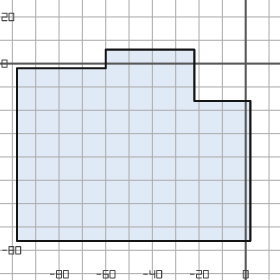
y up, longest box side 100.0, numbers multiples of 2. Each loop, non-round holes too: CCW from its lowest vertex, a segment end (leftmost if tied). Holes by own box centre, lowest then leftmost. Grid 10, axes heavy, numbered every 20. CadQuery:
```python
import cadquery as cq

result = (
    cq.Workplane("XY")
    .moveTo(-98.0, -76.0)
    .lineTo(2.0, -76.0)
    .lineTo(2.0, -16.0)
    .lineTo(-22.0, -16.0)
    .lineTo(-22.0, 6.0)
    .lineTo(-60.0, 6.0)
    .lineTo(-60.0, -2.0)
    .lineTo(-98.0, -2.0)
    .close()
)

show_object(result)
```